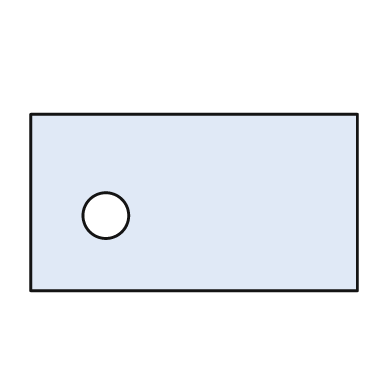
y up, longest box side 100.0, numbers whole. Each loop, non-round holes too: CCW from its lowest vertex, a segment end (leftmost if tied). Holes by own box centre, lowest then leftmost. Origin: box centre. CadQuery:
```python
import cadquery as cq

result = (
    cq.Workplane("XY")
    .moveTo(-50.0, -27.0)
    .lineTo(50.0, -27.0)
    .lineTo(50.0, 27.0)
    .lineTo(-50.0, 27.0)
    .close()
    .moveTo(-27.0, -4.0)
    .circle(7.0)
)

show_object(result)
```